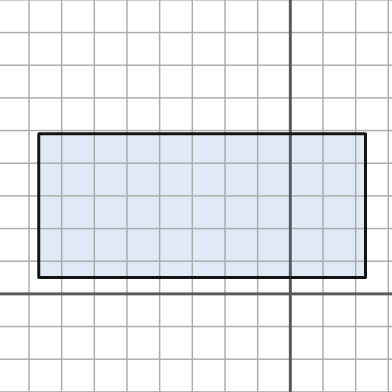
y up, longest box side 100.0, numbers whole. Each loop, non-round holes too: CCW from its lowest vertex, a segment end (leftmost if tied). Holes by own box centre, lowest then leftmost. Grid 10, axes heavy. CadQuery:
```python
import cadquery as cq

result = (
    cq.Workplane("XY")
    .moveTo(-77.0, 5.0)
    .lineTo(23.0, 5.0)
    .lineTo(23.0, 49.0)
    .lineTo(-77.0, 49.0)
    .close()
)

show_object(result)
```